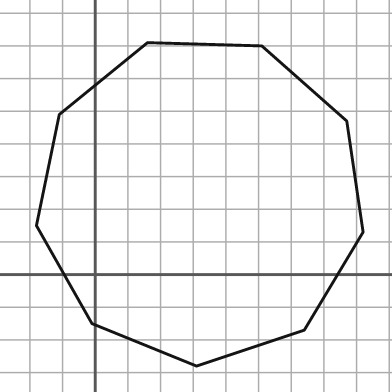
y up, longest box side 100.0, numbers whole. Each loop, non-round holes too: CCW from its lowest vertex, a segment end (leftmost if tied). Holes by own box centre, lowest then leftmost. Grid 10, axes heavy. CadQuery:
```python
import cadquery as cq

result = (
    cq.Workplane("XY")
    .moveTo(31.0, -28.0)
    .lineTo(64.0, -17.0)
    .lineTo(82.0, 13.0)
    .lineTo(77.0, 47.0)
    .lineTo(51.0, 70.0)
    .lineTo(16.0, 71.0)
    .lineTo(-11.0, 49.0)
    .lineTo(-18.0, 15.0)
    .lineTo(-1.0, -15.0)
    .close()
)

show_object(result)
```